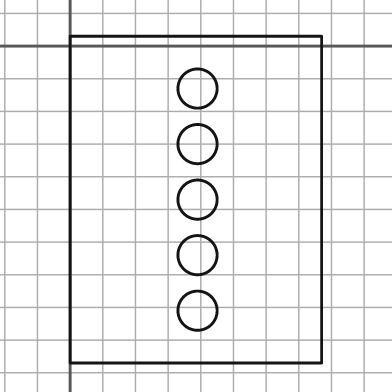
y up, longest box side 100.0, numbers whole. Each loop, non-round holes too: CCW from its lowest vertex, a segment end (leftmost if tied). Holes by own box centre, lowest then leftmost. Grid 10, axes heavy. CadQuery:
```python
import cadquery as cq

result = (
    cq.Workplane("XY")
    .moveTo(0.0, -97.0)
    .lineTo(77.0, -97.0)
    .lineTo(77.0, 3.0)
    .lineTo(0.0, 3.0)
    .close()
    .moveTo(39.0, -81.0)
    .circle(6.0)
    .moveTo(39.0, -64.0)
    .circle(6.0)
    .moveTo(39.0, -47.0)
    .circle(6.0)
    .moveTo(39.0, -30.0)
    .circle(6.0)
    .moveTo(39.0, -13.0)
    .circle(6.0)
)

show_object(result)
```